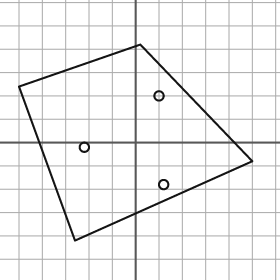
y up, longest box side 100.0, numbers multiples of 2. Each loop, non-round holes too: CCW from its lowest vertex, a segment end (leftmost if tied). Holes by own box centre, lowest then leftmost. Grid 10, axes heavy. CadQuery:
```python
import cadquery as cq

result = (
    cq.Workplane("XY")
    .moveTo(-26.0, -42.0)
    .lineTo(50.0, -8.0)
    .lineTo(2.0, 42.0)
    .lineTo(-50.0, 24.0)
    .close()
    .moveTo(12.0, -18.0)
    .circle(2.0)
    .moveTo(-22.0, -2.0)
    .circle(2.0)
    .moveTo(10.0, 20.0)
    .circle(2.0)
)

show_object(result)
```